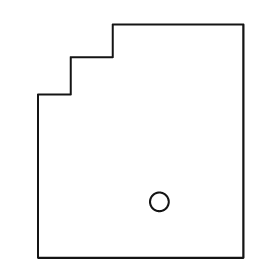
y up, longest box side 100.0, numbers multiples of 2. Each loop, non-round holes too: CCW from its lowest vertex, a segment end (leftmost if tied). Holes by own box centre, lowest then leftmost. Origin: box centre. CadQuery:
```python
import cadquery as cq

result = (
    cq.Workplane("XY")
    .moveTo(-44.0, -50.0)
    .lineTo(44.0, -50.0)
    .lineTo(44.0, 50.0)
    .lineTo(-12.0, 50.0)
    .lineTo(-12.0, 36.0)
    .lineTo(-30.0, 36.0)
    .lineTo(-30.0, 20.0)
    .lineTo(-44.0, 20.0)
    .close()
    .moveTo(8.0, -26.0)
    .circle(4.0)
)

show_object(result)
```